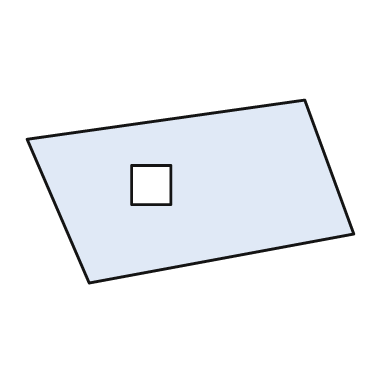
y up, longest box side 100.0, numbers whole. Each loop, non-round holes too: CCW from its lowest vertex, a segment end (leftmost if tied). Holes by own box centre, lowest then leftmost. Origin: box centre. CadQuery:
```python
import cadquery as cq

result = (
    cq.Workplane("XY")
    .moveTo(-31.0, -28.0)
    .lineTo(50.0, -13.0)
    .lineTo(35.0, 28.0)
    .lineTo(-50.0, 16.0)
    .close()
    .moveTo(-18.0, -4.0)
    .lineTo(-6.0, -4.0)
    .lineTo(-6.0, 8.0)
    .lineTo(-18.0, 8.0)
    .close()
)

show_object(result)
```